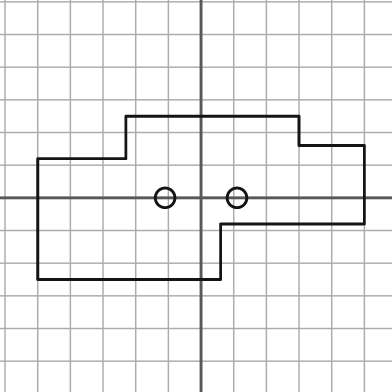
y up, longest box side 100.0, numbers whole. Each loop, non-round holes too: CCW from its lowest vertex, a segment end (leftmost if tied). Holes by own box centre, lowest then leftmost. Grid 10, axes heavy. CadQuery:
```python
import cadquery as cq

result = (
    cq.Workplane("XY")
    .moveTo(-50.0, -25.0)
    .lineTo(6.0, -25.0)
    .lineTo(6.0, -8.0)
    .lineTo(50.0, -8.0)
    .lineTo(50.0, 16.0)
    .lineTo(30.0, 16.0)
    .lineTo(30.0, 25.0)
    .lineTo(-23.0, 25.0)
    .lineTo(-23.0, 12.0)
    .lineTo(-50.0, 12.0)
    .close()
    .moveTo(-11.0, 0.0)
    .circle(3.0)
    .moveTo(11.0, 0.0)
    .circle(3.0)
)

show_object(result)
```